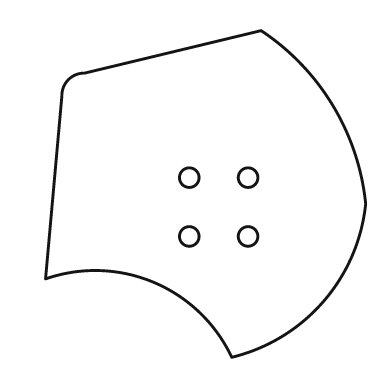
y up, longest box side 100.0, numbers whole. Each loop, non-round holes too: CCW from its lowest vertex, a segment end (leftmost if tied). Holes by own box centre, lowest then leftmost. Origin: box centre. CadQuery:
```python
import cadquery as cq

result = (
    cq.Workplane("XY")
    .moveTo(8.0, -50.0)
    .threePointArc((36.0, -33.0), (49.0, -3.0))
    .threePointArc((39.0, 27.0), (17.0, 50.0))
    .lineTo(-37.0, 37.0)
    .threePointArc((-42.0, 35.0), (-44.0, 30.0))
    .lineTo(-49.0, -26.0)
    .threePointArc((-16.0, -27.0), (8.0, -50.0))
    .close()
    .moveTo(-5.0, -13.0)
    .circle(3.0)
    .moveTo(13.0, -13.0)
    .circle(3.0)
    .moveTo(-5.0, 5.0)
    .circle(3.0)
    .moveTo(13.0, 5.0)
    .circle(3.0)
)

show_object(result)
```